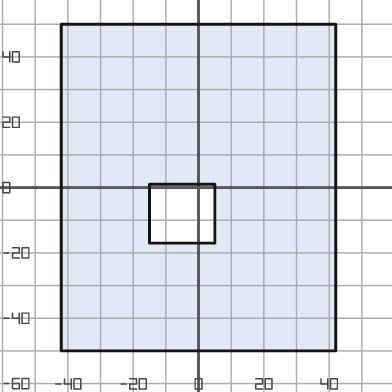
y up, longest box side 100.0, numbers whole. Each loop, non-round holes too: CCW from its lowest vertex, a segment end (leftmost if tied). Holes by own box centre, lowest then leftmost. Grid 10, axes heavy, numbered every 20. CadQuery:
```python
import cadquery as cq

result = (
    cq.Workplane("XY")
    .moveTo(-42.0, -50.0)
    .lineTo(42.0, -50.0)
    .lineTo(42.0, 50.0)
    .lineTo(-42.0, 50.0)
    .close()
    .moveTo(-15.0, -17.0)
    .lineTo(5.0, -17.0)
    .lineTo(5.0, 1.0)
    .lineTo(-15.0, 1.0)
    .close()
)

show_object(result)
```